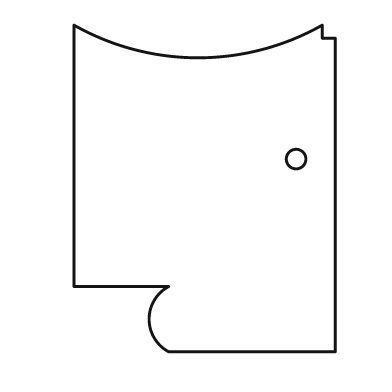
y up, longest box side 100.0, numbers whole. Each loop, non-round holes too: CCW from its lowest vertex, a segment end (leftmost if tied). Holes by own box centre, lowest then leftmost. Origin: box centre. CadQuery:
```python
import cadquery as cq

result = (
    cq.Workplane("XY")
    .moveTo(-11.0, -50.0)
    .lineTo(40.0, -50.0)
    .lineTo(40.0, 46.0)
    .lineTo(36.0, 46.0)
    .lineTo(36.0, 50.0)
    .threePointArc((-2.0, 40.0), (-40.0, 50.0))
    .lineTo(-40.0, -30.0)
    .lineTo(-11.0, -30.0)
    .threePointArc((-17.0, -40.0), (-11.0, -50.0))
    .close()
    .moveTo(28.0, 9.0)
    .circle(3.0)
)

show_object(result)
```